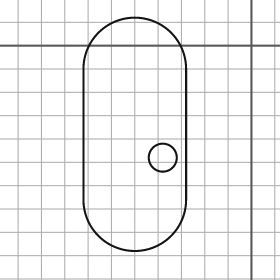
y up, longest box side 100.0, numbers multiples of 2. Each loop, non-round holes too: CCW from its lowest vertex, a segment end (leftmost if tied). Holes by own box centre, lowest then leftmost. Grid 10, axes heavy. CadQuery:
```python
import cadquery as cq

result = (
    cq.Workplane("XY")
    .moveTo(-72.0, -66.0)
    .threePointArc((-50.0, -88.0), (-28.0, -66.0))
    .lineTo(-28.0, -10.0)
    .threePointArc((-50.0, 12.0), (-72.0, -10.0))
    .close()
    .moveTo(-38.0, -48.0)
    .circle(6.0)
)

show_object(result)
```